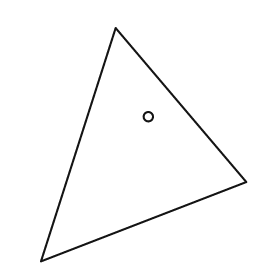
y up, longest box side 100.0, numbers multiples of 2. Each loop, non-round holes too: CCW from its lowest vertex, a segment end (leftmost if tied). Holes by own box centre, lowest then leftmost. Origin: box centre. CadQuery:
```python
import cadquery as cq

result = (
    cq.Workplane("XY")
    .moveTo(-44.0, -50.0)
    .lineTo(44.0, -16.0)
    .lineTo(-12.0, 50.0)
    .close()
    .moveTo(2.0, 12.0)
    .circle(2.0)
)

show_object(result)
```